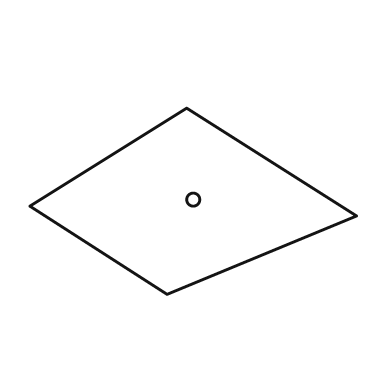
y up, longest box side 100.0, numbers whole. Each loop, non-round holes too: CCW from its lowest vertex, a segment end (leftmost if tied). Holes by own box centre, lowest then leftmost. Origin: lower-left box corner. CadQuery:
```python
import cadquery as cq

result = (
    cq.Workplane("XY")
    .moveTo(42.0, 0.0)
    .lineTo(100.0, 24.0)
    .lineTo(48.0, 57.0)
    .lineTo(0.0, 27.0)
    .close()
    .moveTo(50.0, 29.0)
    .circle(2.0)
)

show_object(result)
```